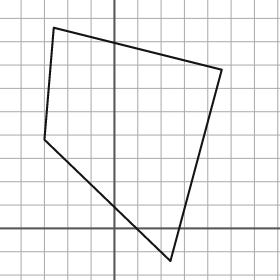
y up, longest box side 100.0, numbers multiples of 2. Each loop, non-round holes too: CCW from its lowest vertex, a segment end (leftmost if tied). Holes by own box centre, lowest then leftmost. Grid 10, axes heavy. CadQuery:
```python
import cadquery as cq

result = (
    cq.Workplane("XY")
    .moveTo(24.0, -14.0)
    .lineTo(46.0, 68.0)
    .lineTo(-26.0, 86.0)
    .lineTo(-30.0, 38.0)
    .close()
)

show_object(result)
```